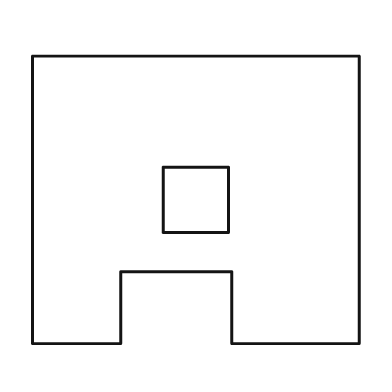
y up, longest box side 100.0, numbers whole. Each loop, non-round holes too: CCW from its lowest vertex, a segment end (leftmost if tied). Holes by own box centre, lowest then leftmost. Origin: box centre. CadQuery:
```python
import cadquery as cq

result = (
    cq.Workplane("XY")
    .moveTo(-50.0, -44.0)
    .lineTo(-23.0, -44.0)
    .lineTo(-23.0, -22.0)
    .lineTo(11.0, -22.0)
    .lineTo(11.0, -44.0)
    .lineTo(50.0, -44.0)
    .lineTo(50.0, 44.0)
    .lineTo(-50.0, 44.0)
    .close()
    .moveTo(-10.0, -10.0)
    .lineTo(10.0, -10.0)
    .lineTo(10.0, 10.0)
    .lineTo(-10.0, 10.0)
    .close()
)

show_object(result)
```